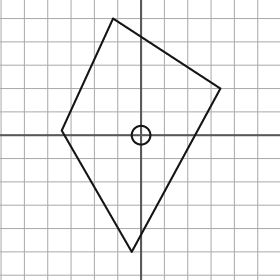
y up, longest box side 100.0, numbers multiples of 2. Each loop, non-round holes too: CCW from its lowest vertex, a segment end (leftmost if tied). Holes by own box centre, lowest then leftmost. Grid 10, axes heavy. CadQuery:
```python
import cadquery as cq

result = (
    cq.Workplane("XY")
    .moveTo(-4.0, -50.0)
    .lineTo(34.0, 20.0)
    .lineTo(-12.0, 50.0)
    .lineTo(-34.0, 2.0)
    .close()
    .moveTo(0.0, 0.0)
    .circle(4.0)
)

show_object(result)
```